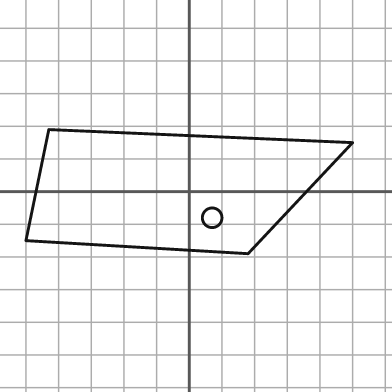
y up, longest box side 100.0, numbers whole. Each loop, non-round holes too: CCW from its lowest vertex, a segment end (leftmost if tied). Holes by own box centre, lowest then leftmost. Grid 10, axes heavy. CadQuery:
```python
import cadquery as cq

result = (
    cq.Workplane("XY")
    .moveTo(18.0, -19.0)
    .lineTo(50.0, 15.0)
    .lineTo(-43.0, 19.0)
    .lineTo(-50.0, -15.0)
    .close()
    .moveTo(7.0, -8.0)
    .circle(3.0)
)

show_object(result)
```